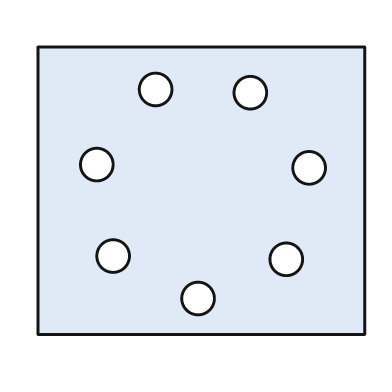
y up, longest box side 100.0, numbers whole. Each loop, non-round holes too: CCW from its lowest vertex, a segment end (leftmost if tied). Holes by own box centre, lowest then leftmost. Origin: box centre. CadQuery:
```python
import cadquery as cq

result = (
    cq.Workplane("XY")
    .moveTo(-50.0, -44.0)
    .lineTo(50.0, -44.0)
    .lineTo(50.0, 44.0)
    .lineTo(-50.0, 44.0)
    .close()
    .moveTo(-1.0, -33.0)
    .circle(5.0)
    .moveTo(26.0, -21.0)
    .circle(5.0)
    .moveTo(-27.0, -20.0)
    .circle(5.0)
    .moveTo(33.0, 7.0)
    .circle(5.0)
    .moveTo(-32.0, 8.0)
    .circle(5.0)
    .moveTo(15.0, 30.0)
    .circle(5.0)
    .moveTo(-14.0, 31.0)
    .circle(5.0)
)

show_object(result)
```